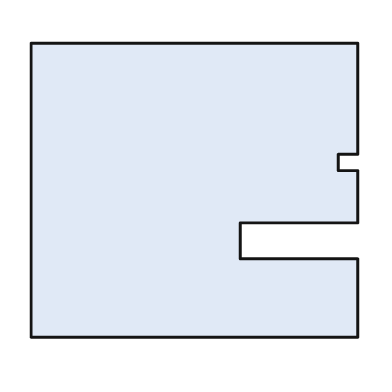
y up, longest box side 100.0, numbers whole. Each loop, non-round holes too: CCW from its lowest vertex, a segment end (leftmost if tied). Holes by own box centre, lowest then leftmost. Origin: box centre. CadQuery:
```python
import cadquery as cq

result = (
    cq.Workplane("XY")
    .moveTo(-50.0, -45.0)
    .lineTo(50.0, -45.0)
    .lineTo(50.0, -21.0)
    .lineTo(14.0, -21.0)
    .lineTo(14.0, -10.0)
    .lineTo(50.0, -10.0)
    .lineTo(50.0, 6.0)
    .lineTo(44.0, 6.0)
    .lineTo(44.0, 11.0)
    .lineTo(50.0, 11.0)
    .lineTo(50.0, 45.0)
    .lineTo(-50.0, 45.0)
    .close()
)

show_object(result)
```